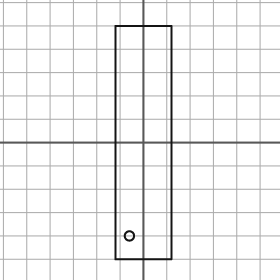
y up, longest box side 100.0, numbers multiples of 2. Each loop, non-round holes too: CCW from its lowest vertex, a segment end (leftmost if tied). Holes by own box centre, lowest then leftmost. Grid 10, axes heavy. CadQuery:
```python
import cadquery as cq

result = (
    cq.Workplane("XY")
    .moveTo(-12.0, -50.0)
    .lineTo(12.0, -50.0)
    .lineTo(12.0, 50.0)
    .lineTo(-12.0, 50.0)
    .close()
    .moveTo(-6.0, -40.0)
    .circle(2.0)
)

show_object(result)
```